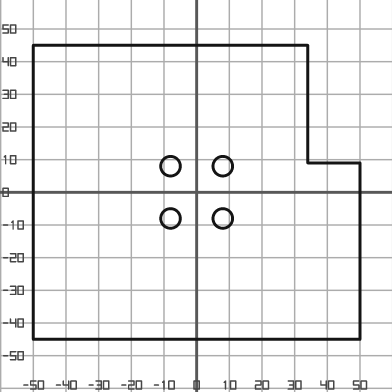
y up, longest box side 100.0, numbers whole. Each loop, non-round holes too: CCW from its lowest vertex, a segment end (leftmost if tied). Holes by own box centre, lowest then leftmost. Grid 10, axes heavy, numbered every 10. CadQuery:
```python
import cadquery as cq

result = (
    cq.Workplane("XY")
    .moveTo(-50.0, -45.0)
    .lineTo(50.0, -45.0)
    .lineTo(50.0, 9.0)
    .lineTo(34.0, 9.0)
    .lineTo(34.0, 45.0)
    .lineTo(-50.0, 45.0)
    .close()
    .moveTo(-8.0, -8.0)
    .circle(3.0)
    .moveTo(8.0, -8.0)
    .circle(3.0)
    .moveTo(-8.0, 8.0)
    .circle(3.0)
    .moveTo(8.0, 8.0)
    .circle(3.0)
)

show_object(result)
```